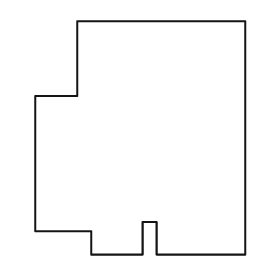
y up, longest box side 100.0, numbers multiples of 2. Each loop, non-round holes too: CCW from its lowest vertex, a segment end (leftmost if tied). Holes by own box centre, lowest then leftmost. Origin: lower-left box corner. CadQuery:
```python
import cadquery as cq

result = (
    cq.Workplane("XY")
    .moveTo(24.0, 0.0)
    .lineTo(46.0, 0.0)
    .lineTo(46.0, 14.0)
    .lineTo(52.0, 14.0)
    .lineTo(52.0, 0.0)
    .lineTo(90.0, 0.0)
    .lineTo(90.0, 100.0)
    .lineTo(18.0, 100.0)
    .lineTo(18.0, 68.0)
    .lineTo(0.0, 68.0)
    .lineTo(0.0, 10.0)
    .lineTo(24.0, 10.0)
    .close()
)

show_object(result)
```